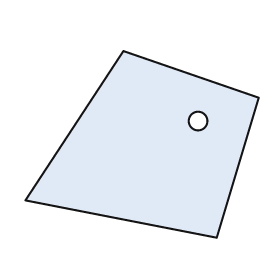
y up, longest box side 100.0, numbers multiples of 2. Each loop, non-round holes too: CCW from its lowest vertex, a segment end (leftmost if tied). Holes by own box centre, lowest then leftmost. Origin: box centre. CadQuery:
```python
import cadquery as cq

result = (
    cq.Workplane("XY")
    .moveTo(32.0, -40.0)
    .lineTo(50.0, 20.0)
    .lineTo(-8.0, 40.0)
    .lineTo(-50.0, -24.0)
    .close()
    .moveTo(24.0, 10.0)
    .circle(4.0)
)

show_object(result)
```